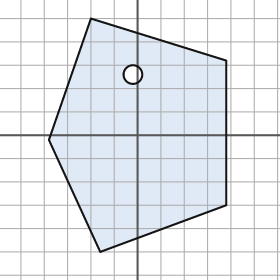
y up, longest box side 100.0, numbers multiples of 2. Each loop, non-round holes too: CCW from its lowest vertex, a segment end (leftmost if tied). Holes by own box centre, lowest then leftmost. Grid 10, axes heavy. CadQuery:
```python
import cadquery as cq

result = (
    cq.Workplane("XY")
    .moveTo(-16.0, -50.0)
    .lineTo(38.0, -30.0)
    .lineTo(38.0, 32.0)
    .lineTo(-20.0, 50.0)
    .lineTo(-38.0, -2.0)
    .close()
    .moveTo(-2.0, 26.0)
    .circle(4.0)
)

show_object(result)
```